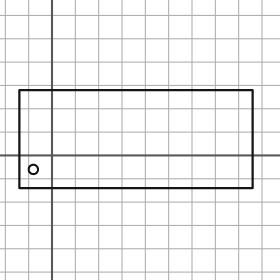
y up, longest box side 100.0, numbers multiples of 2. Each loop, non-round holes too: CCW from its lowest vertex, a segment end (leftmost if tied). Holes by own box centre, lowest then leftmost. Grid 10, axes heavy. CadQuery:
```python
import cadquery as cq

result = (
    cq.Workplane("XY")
    .moveTo(-14.0, -14.0)
    .lineTo(86.0, -14.0)
    .lineTo(86.0, 28.0)
    .lineTo(-14.0, 28.0)
    .close()
    .moveTo(-8.0, -6.0)
    .circle(2.0)
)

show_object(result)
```